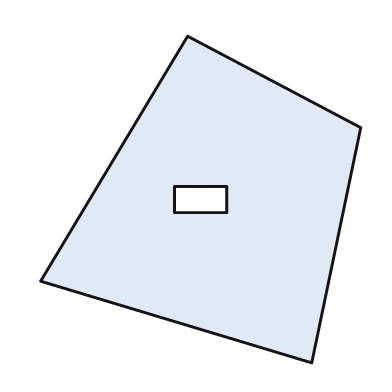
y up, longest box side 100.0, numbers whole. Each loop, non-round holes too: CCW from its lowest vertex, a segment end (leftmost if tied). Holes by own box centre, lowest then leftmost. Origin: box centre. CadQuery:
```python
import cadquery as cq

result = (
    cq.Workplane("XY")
    .moveTo(34.0, -50.0)
    .lineTo(49.0, 22.0)
    .lineTo(-4.0, 50.0)
    .lineTo(-49.0, -25.0)
    .close()
    .moveTo(-8.0, -4.0)
    .lineTo(8.0, -4.0)
    .lineTo(8.0, 4.0)
    .lineTo(-8.0, 4.0)
    .close()
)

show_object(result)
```